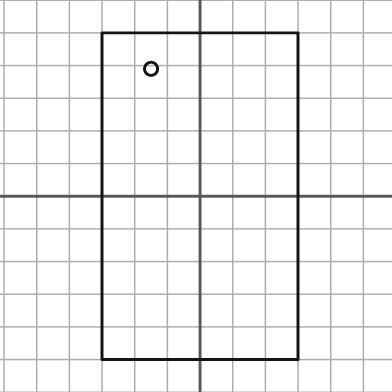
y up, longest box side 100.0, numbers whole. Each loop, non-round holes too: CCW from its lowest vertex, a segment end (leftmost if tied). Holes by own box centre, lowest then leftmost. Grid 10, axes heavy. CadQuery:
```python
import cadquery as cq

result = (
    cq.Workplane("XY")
    .moveTo(-30.0, -50.0)
    .lineTo(30.0, -50.0)
    .lineTo(30.0, 50.0)
    .lineTo(-30.0, 50.0)
    .close()
    .moveTo(-15.0, 39.0)
    .circle(2.0)
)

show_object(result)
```